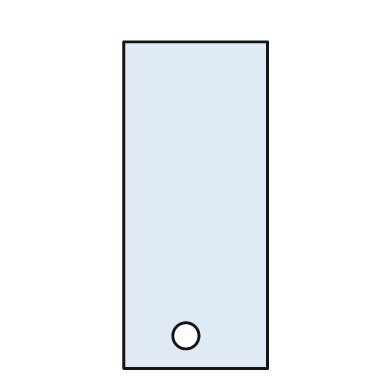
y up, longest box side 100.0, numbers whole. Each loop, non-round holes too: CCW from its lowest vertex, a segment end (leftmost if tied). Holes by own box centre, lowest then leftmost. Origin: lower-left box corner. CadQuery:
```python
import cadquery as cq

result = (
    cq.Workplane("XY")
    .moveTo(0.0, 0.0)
    .lineTo(44.0, 0.0)
    .lineTo(44.0, 100.0)
    .lineTo(0.0, 100.0)
    .close()
    .moveTo(19.0, 10.0)
    .circle(4.0)
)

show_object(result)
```